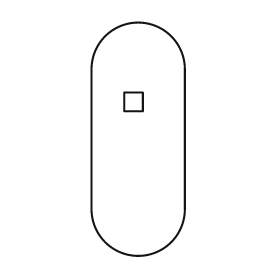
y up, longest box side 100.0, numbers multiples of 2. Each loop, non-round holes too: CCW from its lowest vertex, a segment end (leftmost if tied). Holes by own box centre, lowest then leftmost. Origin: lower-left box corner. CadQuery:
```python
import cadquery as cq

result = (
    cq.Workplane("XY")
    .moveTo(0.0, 20.0)
    .threePointArc((20.0, 0.0), (40.0, 20.0))
    .lineTo(40.0, 80.0)
    .threePointArc((20.0, 100.0), (0.0, 80.0))
    .close()
    .moveTo(14.0, 62.0)
    .lineTo(22.0, 62.0)
    .lineTo(22.0, 70.0)
    .lineTo(14.0, 70.0)
    .close()
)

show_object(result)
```